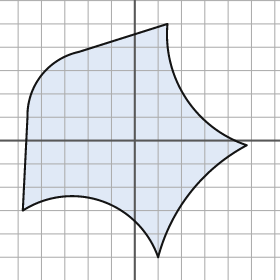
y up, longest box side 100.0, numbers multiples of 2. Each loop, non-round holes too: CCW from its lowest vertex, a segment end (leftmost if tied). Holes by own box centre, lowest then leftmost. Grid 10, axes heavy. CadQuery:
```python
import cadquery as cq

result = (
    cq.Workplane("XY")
    .moveTo(10.0, -50.0)
    .threePointArc((24.0, -22.0), (48.0, -2.0))
    .threePointArc((22.0, 18.0), (14.0, 50.0))
    .lineTo(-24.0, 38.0)
    .threePointArc((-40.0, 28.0), (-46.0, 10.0))
    .lineTo(-48.0, -30.0)
    .threePointArc((-14.0, -26.0), (10.0, -50.0))
    .close()
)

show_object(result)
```